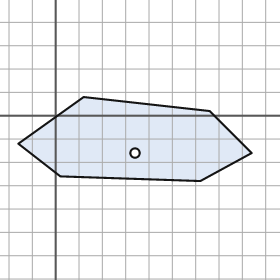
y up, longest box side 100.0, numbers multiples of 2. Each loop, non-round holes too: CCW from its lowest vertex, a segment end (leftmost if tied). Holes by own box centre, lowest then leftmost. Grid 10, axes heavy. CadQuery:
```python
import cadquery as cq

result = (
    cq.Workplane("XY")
    .moveTo(62.0, -28.0)
    .lineTo(84.0, -16.0)
    .lineTo(66.0, 2.0)
    .lineTo(12.0, 8.0)
    .lineTo(-16.0, -12.0)
    .lineTo(2.0, -26.0)
    .close()
    .moveTo(34.0, -16.0)
    .circle(2.0)
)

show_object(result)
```